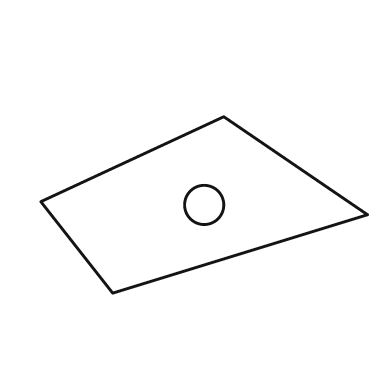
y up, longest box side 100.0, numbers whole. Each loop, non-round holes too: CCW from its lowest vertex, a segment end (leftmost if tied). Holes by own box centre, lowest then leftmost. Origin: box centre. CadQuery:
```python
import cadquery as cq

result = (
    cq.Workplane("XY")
    .moveTo(-28.0, -27.0)
    .lineTo(50.0, -3.0)
    .lineTo(6.0, 27.0)
    .lineTo(-50.0, 1.0)
    .close()
    .moveTo(0.0, 0.0)
    .circle(6.0)
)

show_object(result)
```